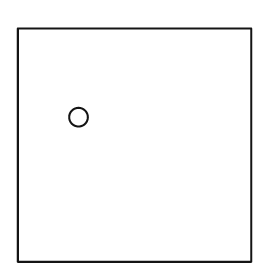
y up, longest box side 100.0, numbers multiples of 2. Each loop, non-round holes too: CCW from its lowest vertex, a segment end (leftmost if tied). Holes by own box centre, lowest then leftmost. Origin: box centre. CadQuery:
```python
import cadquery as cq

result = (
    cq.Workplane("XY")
    .moveTo(-50.0, -50.0)
    .lineTo(50.0, -50.0)
    .lineTo(50.0, 50.0)
    .lineTo(-50.0, 50.0)
    .close()
    .moveTo(-24.0, 12.0)
    .circle(4.0)
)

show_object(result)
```